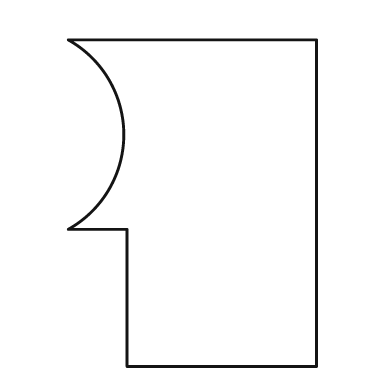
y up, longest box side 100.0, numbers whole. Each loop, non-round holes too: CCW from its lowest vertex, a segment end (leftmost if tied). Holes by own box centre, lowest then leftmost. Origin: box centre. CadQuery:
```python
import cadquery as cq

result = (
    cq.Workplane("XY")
    .moveTo(-20.0, -50.0)
    .lineTo(38.0, -50.0)
    .lineTo(38.0, 50.0)
    .lineTo(-38.0, 50.0)
    .threePointArc((-21.0, 21.0), (-38.0, -8.0))
    .lineTo(-20.0, -8.0)
    .close()
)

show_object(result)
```